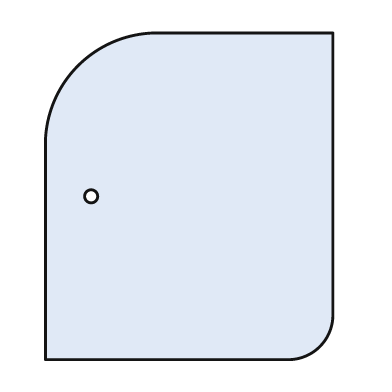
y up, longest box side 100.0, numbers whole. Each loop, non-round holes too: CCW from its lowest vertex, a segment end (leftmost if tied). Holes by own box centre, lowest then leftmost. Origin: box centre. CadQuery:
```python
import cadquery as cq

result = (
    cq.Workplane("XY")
    .moveTo(-44.0, -50.0)
    .lineTo(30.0, -50.0)
    .threePointArc((40.0, -46.0), (44.0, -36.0))
    .lineTo(44.0, 50.0)
    .lineTo(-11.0, 50.0)
    .threePointArc((-34.0, 40.0), (-44.0, 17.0))
    .close()
    .moveTo(-30.0, 0.0)
    .circle(2.0)
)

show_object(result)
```